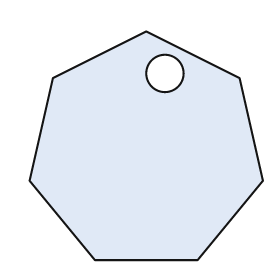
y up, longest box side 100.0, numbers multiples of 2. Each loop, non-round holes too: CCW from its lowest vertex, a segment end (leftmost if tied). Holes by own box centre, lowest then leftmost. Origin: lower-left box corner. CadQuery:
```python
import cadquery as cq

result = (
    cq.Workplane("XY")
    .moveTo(28.0, 0.0)
    .lineTo(72.0, 0.0)
    .lineTo(100.0, 34.0)
    .lineTo(90.0, 78.0)
    .lineTo(50.0, 98.0)
    .lineTo(10.0, 78.0)
    .lineTo(0.0, 34.0)
    .close()
    .moveTo(58.0, 80.0)
    .circle(8.0)
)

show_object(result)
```